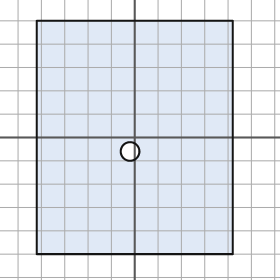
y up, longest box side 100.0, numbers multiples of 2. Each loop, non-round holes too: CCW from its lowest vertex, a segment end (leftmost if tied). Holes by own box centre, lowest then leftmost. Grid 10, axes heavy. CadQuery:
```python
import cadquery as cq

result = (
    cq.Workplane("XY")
    .moveTo(-42.0, -50.0)
    .lineTo(42.0, -50.0)
    .lineTo(42.0, 50.0)
    .lineTo(-42.0, 50.0)
    .close()
    .moveTo(-2.0, -6.0)
    .circle(4.0)
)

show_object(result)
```